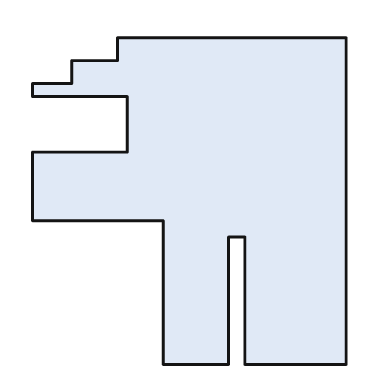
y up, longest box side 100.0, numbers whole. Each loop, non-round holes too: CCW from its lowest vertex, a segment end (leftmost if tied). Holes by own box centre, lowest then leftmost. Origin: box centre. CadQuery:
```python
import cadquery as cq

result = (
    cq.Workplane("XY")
    .moveTo(-8.0, -50.0)
    .lineTo(12.0, -50.0)
    .lineTo(12.0, -11.0)
    .lineTo(17.0, -11.0)
    .lineTo(17.0, -50.0)
    .lineTo(48.0, -50.0)
    .lineTo(48.0, 50.0)
    .lineTo(-22.0, 50.0)
    .lineTo(-22.0, 43.0)
    .lineTo(-36.0, 43.0)
    .lineTo(-36.0, 36.0)
    .lineTo(-48.0, 36.0)
    .lineTo(-48.0, 32.0)
    .lineTo(-19.0, 32.0)
    .lineTo(-19.0, 15.0)
    .lineTo(-48.0, 15.0)
    .lineTo(-48.0, -6.0)
    .lineTo(-8.0, -6.0)
    .close()
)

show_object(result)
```